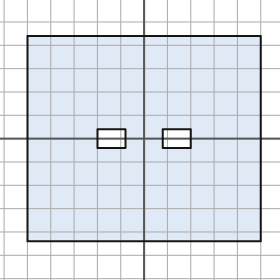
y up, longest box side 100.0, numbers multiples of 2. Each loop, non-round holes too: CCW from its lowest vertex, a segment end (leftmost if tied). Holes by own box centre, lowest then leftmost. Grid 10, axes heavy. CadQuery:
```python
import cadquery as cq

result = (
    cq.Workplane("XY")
    .moveTo(-50.0, -44.0)
    .lineTo(50.0, -44.0)
    .lineTo(50.0, 44.0)
    .lineTo(-50.0, 44.0)
    .close()
    .moveTo(-20.0, -4.0)
    .lineTo(-8.0, -4.0)
    .lineTo(-8.0, 4.0)
    .lineTo(-20.0, 4.0)
    .close()
    .moveTo(8.0, -4.0)
    .lineTo(20.0, -4.0)
    .lineTo(20.0, 4.0)
    .lineTo(8.0, 4.0)
    .close()
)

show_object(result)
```